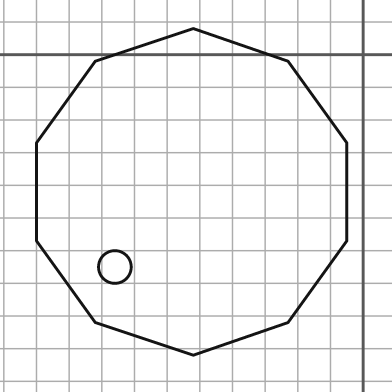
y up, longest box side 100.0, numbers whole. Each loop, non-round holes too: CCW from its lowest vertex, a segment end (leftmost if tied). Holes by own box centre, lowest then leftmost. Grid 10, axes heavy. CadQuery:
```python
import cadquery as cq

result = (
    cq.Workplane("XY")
    .moveTo(-52.0, -92.0)
    .lineTo(-23.0, -82.0)
    .lineTo(-5.0, -57.0)
    .lineTo(-5.0, -27.0)
    .lineTo(-23.0, -2.0)
    .lineTo(-52.0, 8.0)
    .lineTo(-82.0, -2.0)
    .lineTo(-100.0, -27.0)
    .lineTo(-100.0, -57.0)
    .lineTo(-82.0, -82.0)
    .close()
    .moveTo(-76.0, -65.0)
    .circle(5.0)
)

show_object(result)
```